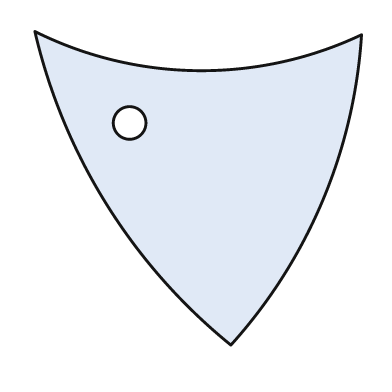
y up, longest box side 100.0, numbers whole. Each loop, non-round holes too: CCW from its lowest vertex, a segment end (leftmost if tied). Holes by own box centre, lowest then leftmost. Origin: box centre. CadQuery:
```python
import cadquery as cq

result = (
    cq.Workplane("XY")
    .moveTo(10.0, -48.0)
    .threePointArc((38.0, -4.0), (50.0, 47.0))
    .threePointArc((0.0, 36.0), (-50.0, 48.0))
    .threePointArc((-28.0, -5.0), (10.0, -48.0))
    .close()
    .moveTo(-21.0, 20.0)
    .circle(5.0)
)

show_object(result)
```